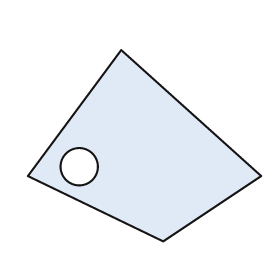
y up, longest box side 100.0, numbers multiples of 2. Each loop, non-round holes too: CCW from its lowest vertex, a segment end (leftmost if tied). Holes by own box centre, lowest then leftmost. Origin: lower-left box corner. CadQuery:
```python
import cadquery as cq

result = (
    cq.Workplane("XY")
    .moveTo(58.0, 0.0)
    .lineTo(100.0, 28.0)
    .lineTo(40.0, 82.0)
    .lineTo(0.0, 28.0)
    .close()
    .moveTo(22.0, 32.0)
    .circle(8.0)
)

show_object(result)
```